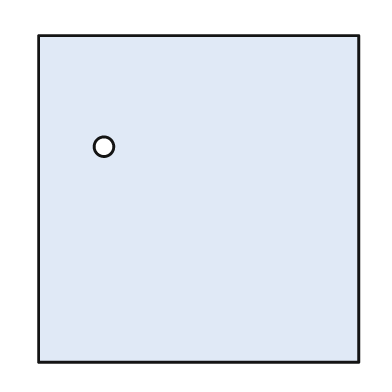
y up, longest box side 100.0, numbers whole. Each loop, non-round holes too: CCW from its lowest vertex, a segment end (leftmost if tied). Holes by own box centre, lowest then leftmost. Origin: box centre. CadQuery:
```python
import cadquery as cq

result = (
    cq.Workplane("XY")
    .moveTo(-49.0, -50.0)
    .lineTo(49.0, -50.0)
    .lineTo(49.0, 50.0)
    .lineTo(-49.0, 50.0)
    .close()
    .moveTo(-29.0, 16.0)
    .circle(3.0)
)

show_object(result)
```